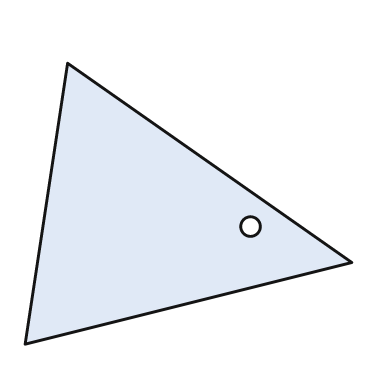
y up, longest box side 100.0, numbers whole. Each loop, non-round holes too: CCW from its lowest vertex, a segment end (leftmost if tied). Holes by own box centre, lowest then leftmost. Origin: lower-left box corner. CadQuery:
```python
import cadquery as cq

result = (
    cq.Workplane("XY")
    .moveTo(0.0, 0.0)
    .lineTo(100.0, 25.0)
    .lineTo(13.0, 86.0)
    .close()
    .moveTo(69.0, 36.0)
    .circle(3.0)
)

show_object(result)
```